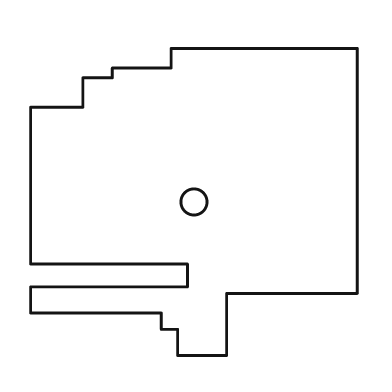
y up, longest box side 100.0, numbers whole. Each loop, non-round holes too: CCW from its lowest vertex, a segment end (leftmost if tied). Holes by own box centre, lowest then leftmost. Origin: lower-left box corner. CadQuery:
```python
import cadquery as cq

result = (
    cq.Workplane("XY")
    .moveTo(45.0, 0.0)
    .lineTo(60.0, 0.0)
    .lineTo(60.0, 19.0)
    .lineTo(100.0, 19.0)
    .lineTo(100.0, 94.0)
    .lineTo(43.0, 94.0)
    .lineTo(43.0, 88.0)
    .lineTo(25.0, 88.0)
    .lineTo(25.0, 85.0)
    .lineTo(16.0, 85.0)
    .lineTo(16.0, 76.0)
    .lineTo(0.0, 76.0)
    .lineTo(0.0, 28.0)
    .lineTo(48.0, 28.0)
    .lineTo(48.0, 21.0)
    .lineTo(0.0, 21.0)
    .lineTo(0.0, 13.0)
    .lineTo(40.0, 13.0)
    .lineTo(40.0, 8.0)
    .lineTo(45.0, 8.0)
    .close()
    .moveTo(50.0, 47.0)
    .circle(4.0)
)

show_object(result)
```